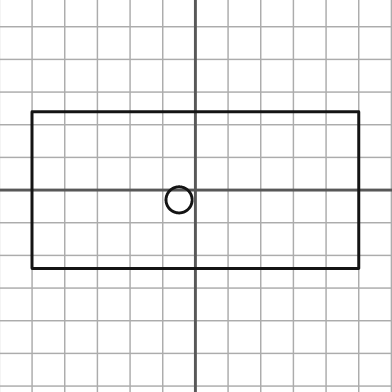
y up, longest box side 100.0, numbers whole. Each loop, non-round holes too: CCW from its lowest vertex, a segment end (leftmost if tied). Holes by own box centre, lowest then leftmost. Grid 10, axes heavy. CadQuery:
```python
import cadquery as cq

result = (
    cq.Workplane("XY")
    .moveTo(-50.0, -24.0)
    .lineTo(50.0, -24.0)
    .lineTo(50.0, 24.0)
    .lineTo(-50.0, 24.0)
    .close()
    .moveTo(-5.0, -3.0)
    .circle(4.0)
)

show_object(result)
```